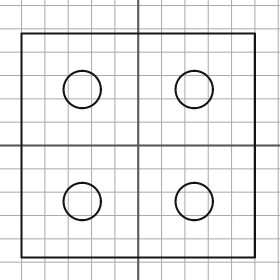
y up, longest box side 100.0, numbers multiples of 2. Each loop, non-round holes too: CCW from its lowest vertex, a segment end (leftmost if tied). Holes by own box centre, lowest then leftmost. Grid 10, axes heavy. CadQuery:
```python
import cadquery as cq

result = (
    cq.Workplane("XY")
    .moveTo(-50.0, -48.0)
    .lineTo(50.0, -48.0)
    .lineTo(50.0, 48.0)
    .lineTo(-50.0, 48.0)
    .close()
    .moveTo(-24.0, -24.0)
    .circle(8.0)
    .moveTo(24.0, -24.0)
    .circle(8.0)
    .moveTo(-24.0, 24.0)
    .circle(8.0)
    .moveTo(24.0, 24.0)
    .circle(8.0)
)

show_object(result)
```